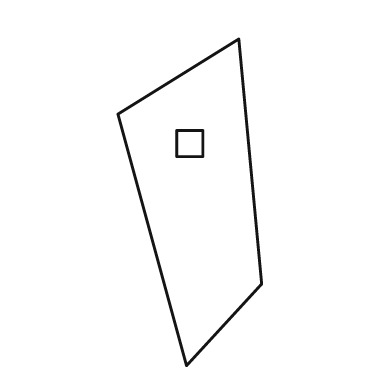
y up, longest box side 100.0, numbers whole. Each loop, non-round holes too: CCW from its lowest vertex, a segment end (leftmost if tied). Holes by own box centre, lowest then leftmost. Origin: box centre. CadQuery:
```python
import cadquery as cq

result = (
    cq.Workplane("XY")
    .moveTo(-1.0, -50.0)
    .lineTo(22.0, -25.0)
    .lineTo(15.0, 50.0)
    .lineTo(-22.0, 27.0)
    .close()
    .moveTo(-4.0, 14.0)
    .lineTo(4.0, 14.0)
    .lineTo(4.0, 22.0)
    .lineTo(-4.0, 22.0)
    .close()
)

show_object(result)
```